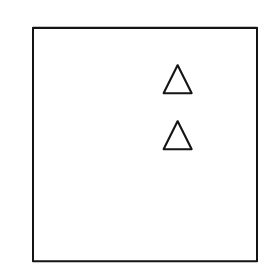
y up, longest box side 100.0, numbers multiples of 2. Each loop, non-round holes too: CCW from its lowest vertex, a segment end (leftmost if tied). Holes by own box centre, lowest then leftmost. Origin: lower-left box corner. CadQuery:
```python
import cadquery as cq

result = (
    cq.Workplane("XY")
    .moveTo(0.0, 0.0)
    .lineTo(96.0, 0.0)
    .lineTo(96.0, 100.0)
    .lineTo(0.0, 100.0)
    .close()
    .moveTo(56.0, 48.0)
    .lineTo(68.0, 48.0)
    .lineTo(62.0, 60.0)
    .close()
    .moveTo(56.0, 72.0)
    .lineTo(68.0, 72.0)
    .lineTo(62.0, 84.0)
    .close()
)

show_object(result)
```